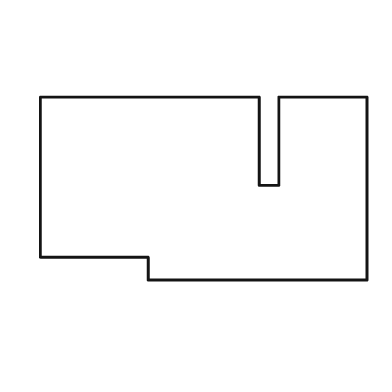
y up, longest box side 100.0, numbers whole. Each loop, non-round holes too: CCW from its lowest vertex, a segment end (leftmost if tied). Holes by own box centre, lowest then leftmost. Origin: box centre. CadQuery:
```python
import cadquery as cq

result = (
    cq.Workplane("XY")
    .moveTo(-17.0, -28.0)
    .lineTo(50.0, -28.0)
    .lineTo(50.0, 28.0)
    .lineTo(23.0, 28.0)
    .lineTo(23.0, 1.0)
    .lineTo(17.0, 1.0)
    .lineTo(17.0, 28.0)
    .lineTo(-50.0, 28.0)
    .lineTo(-50.0, -21.0)
    .lineTo(-17.0, -21.0)
    .close()
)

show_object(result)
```